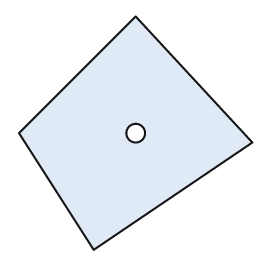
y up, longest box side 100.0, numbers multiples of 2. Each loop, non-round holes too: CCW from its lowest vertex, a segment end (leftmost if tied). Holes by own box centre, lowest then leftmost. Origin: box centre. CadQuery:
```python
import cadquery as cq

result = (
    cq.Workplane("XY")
    .moveTo(-18.0, -50.0)
    .lineTo(50.0, -4.0)
    .lineTo(0.0, 50.0)
    .lineTo(-50.0, 0.0)
    .close()
    .moveTo(0.0, 0.0)
    .circle(4.0)
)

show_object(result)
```